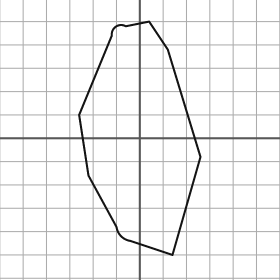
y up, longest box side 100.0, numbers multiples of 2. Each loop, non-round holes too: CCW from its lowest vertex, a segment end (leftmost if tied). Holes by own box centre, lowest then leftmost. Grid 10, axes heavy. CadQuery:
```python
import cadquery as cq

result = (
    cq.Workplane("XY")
    .moveTo(14.0, -50.0)
    .lineTo(26.0, -8.0)
    .lineTo(12.0, 38.0)
    .lineTo(4.0, 50.0)
    .lineTo(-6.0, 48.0)
    .threePointArc((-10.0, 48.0), (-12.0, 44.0))
    .lineTo(-26.0, 10.0)
    .lineTo(-22.0, -16.0)
    .lineTo(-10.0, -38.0)
    .threePointArc((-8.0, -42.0), (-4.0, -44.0))
    .close()
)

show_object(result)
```